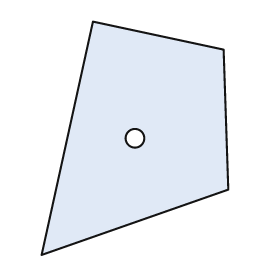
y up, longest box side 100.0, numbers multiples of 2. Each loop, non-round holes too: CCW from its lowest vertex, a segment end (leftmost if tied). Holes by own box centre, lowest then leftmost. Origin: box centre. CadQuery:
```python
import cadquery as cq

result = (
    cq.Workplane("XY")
    .moveTo(-40.0, -50.0)
    .lineTo(40.0, -22.0)
    .lineTo(38.0, 38.0)
    .lineTo(-18.0, 50.0)
    .close()
    .moveTo(0.0, 0.0)
    .circle(4.0)
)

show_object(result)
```